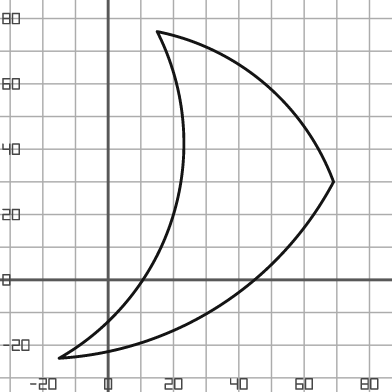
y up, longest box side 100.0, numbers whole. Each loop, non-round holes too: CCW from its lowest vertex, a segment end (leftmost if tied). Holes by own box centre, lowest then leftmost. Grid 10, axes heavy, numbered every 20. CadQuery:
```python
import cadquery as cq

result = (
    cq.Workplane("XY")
    .moveTo(-15.0, -24.0)
    .threePointArc((34.0, -8.0), (69.0, 30.0))
    .threePointArc((48.0, 60.0), (15.0, 76.0))
    .threePointArc((20.0, 20.0), (-15.0, -24.0))
    .close()
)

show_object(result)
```